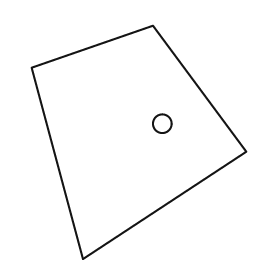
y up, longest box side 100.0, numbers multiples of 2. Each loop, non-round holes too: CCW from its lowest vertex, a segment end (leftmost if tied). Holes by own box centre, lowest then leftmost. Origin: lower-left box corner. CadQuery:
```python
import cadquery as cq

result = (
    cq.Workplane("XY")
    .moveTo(22.0, 0.0)
    .lineTo(92.0, 46.0)
    .lineTo(52.0, 100.0)
    .lineTo(0.0, 82.0)
    .close()
    .moveTo(56.0, 58.0)
    .circle(4.0)
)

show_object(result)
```